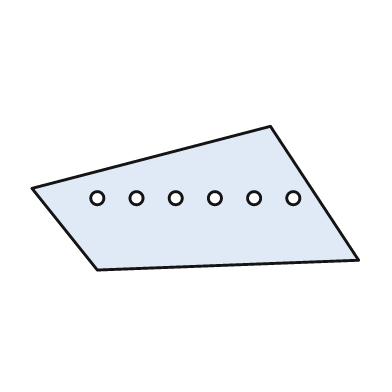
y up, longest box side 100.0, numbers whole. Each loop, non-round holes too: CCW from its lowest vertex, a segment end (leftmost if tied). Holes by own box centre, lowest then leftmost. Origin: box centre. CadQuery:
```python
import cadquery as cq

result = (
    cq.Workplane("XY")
    .moveTo(-30.0, -22.0)
    .lineTo(50.0, -19.0)
    .lineTo(23.0, 22.0)
    .lineTo(-50.0, 3.0)
    .close()
    .moveTo(-30.0, 0.0)
    .circle(2.0)
    .moveTo(-18.0, 0.0)
    .circle(2.0)
    .moveTo(-6.0, 0.0)
    .circle(2.0)
    .moveTo(6.0, 0.0)
    .circle(2.0)
    .moveTo(18.0, 0.0)
    .circle(2.0)
    .moveTo(30.0, 0.0)
    .circle(2.0)
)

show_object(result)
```